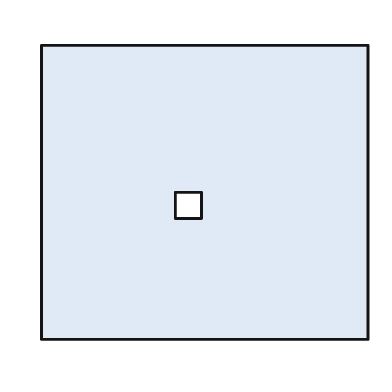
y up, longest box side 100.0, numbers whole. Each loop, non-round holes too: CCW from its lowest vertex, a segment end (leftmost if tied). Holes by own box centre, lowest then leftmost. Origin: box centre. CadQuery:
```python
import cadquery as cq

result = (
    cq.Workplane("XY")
    .moveTo(-50.0, -45.0)
    .lineTo(50.0, -45.0)
    .lineTo(50.0, 45.0)
    .lineTo(-50.0, 45.0)
    .close()
    .moveTo(-9.0, -8.0)
    .lineTo(-1.0, -8.0)
    .lineTo(-1.0, 0.0)
    .lineTo(-9.0, 0.0)
    .close()
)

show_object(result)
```